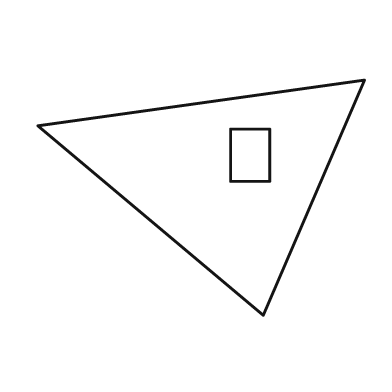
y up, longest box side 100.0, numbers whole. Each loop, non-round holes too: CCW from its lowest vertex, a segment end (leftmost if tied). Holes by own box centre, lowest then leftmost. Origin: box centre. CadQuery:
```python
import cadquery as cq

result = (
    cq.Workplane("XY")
    .moveTo(19.0, -36.0)
    .lineTo(50.0, 36.0)
    .lineTo(-50.0, 22.0)
    .close()
    .moveTo(9.0, 5.0)
    .lineTo(21.0, 5.0)
    .lineTo(21.0, 21.0)
    .lineTo(9.0, 21.0)
    .close()
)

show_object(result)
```